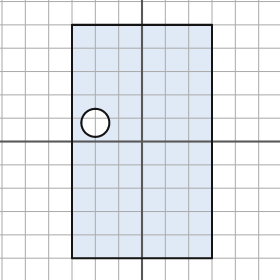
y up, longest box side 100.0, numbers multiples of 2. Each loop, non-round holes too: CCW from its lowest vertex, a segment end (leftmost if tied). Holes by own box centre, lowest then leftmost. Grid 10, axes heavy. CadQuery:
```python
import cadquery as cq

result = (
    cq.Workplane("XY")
    .moveTo(-30.0, -50.0)
    .lineTo(30.0, -50.0)
    .lineTo(30.0, 50.0)
    .lineTo(-30.0, 50.0)
    .close()
    .moveTo(-20.0, 8.0)
    .circle(6.0)
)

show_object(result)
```